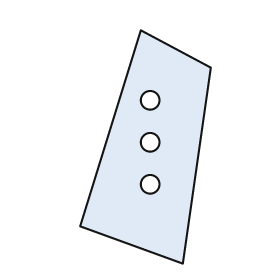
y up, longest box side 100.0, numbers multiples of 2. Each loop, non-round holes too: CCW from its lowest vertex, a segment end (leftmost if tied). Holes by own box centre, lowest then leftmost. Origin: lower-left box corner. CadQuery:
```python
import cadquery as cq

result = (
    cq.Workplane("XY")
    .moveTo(44.0, 0.0)
    .lineTo(56.0, 84.0)
    .lineTo(26.0, 100.0)
    .lineTo(0.0, 16.0)
    .close()
    .moveTo(30.0, 34.0)
    .circle(4.0)
    .moveTo(30.0, 52.0)
    .circle(4.0)
    .moveTo(30.0, 70.0)
    .circle(4.0)
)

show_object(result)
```